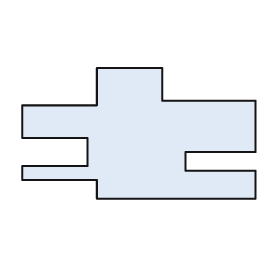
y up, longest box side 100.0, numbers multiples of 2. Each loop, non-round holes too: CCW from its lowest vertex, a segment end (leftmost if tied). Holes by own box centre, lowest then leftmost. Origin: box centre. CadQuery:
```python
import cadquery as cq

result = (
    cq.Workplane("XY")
    .moveTo(-18.0, -28.0)
    .lineTo(50.0, -28.0)
    .lineTo(50.0, -16.0)
    .lineTo(20.0, -16.0)
    .lineTo(20.0, -8.0)
    .lineTo(50.0, -8.0)
    .lineTo(50.0, 14.0)
    .lineTo(10.0, 14.0)
    .lineTo(10.0, 28.0)
    .lineTo(-18.0, 28.0)
    .lineTo(-18.0, 12.0)
    .lineTo(-50.0, 12.0)
    .lineTo(-50.0, -2.0)
    .lineTo(-22.0, -2.0)
    .lineTo(-22.0, -14.0)
    .lineTo(-50.0, -14.0)
    .lineTo(-50.0, -20.0)
    .lineTo(-18.0, -20.0)
    .close()
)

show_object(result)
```